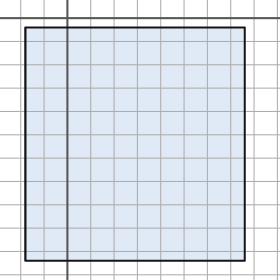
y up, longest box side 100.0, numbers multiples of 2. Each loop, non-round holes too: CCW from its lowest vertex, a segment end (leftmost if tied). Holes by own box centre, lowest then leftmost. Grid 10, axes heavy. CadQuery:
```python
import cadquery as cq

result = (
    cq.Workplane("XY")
    .moveTo(-18.0, -104.0)
    .lineTo(76.0, -104.0)
    .lineTo(76.0, -4.0)
    .lineTo(-18.0, -4.0)
    .close()
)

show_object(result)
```